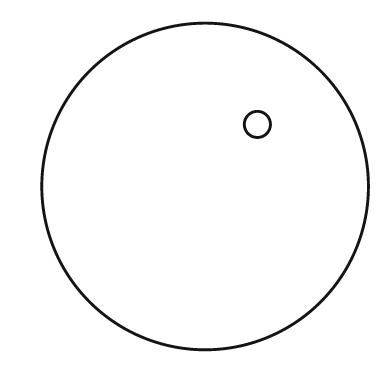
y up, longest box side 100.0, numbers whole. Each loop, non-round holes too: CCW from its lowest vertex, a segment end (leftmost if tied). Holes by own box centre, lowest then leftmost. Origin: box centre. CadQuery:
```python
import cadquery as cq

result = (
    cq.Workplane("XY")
    .moveTo(0.0, 0.0)
    .circle(50.0)
    .moveTo(16.0, 19.0)
    .circle(4.0)
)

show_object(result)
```